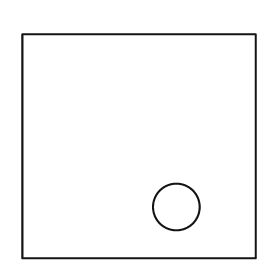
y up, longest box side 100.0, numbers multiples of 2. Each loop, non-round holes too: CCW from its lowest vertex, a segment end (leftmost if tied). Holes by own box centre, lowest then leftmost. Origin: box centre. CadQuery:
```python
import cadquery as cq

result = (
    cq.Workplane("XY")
    .moveTo(-50.0, -48.0)
    .lineTo(50.0, -48.0)
    .lineTo(50.0, 48.0)
    .lineTo(-50.0, 48.0)
    .close()
    .moveTo(16.0, -26.0)
    .circle(10.0)
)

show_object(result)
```